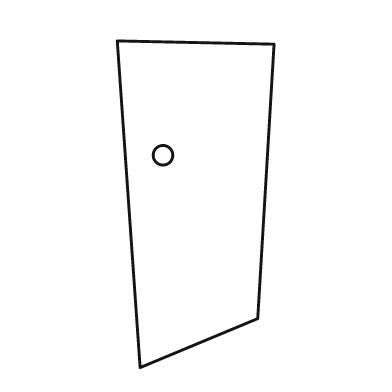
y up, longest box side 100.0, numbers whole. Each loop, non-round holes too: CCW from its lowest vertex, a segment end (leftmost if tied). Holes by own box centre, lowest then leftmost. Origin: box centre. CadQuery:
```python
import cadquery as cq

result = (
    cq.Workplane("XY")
    .moveTo(-17.0, -50.0)
    .lineTo(19.0, -35.0)
    .lineTo(24.0, 49.0)
    .lineTo(-24.0, 50.0)
    .close()
    .moveTo(-10.0, 15.0)
    .circle(3.0)
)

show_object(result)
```